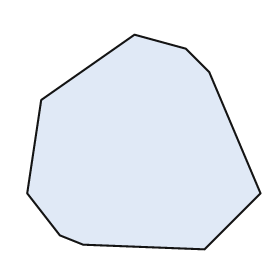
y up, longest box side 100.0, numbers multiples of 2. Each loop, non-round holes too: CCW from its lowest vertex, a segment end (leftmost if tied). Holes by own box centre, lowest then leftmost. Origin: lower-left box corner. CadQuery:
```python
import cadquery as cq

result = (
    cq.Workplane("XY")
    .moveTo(76.0, 0.0)
    .lineTo(100.0, 24.0)
    .lineTo(78.0, 76.0)
    .lineTo(68.0, 86.0)
    .lineTo(46.0, 92.0)
    .lineTo(6.0, 64.0)
    .lineTo(0.0, 24.0)
    .lineTo(14.0, 6.0)
    .lineTo(24.0, 2.0)
    .close()
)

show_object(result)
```